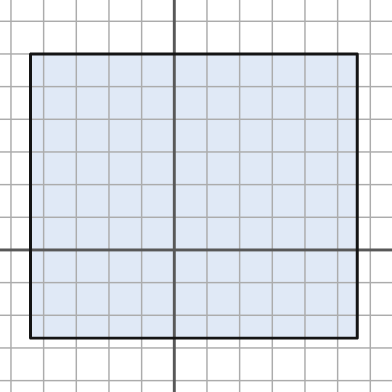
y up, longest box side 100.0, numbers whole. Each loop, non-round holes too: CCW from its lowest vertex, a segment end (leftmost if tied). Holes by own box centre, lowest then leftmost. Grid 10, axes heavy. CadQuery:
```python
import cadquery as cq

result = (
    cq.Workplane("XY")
    .moveTo(-44.0, -27.0)
    .lineTo(56.0, -27.0)
    .lineTo(56.0, 60.0)
    .lineTo(-44.0, 60.0)
    .close()
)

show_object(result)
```